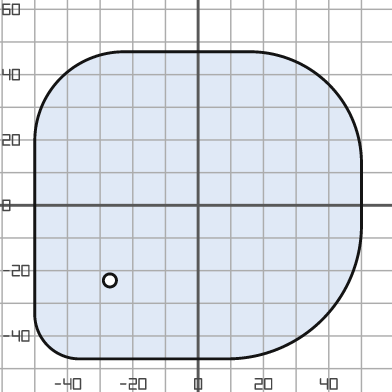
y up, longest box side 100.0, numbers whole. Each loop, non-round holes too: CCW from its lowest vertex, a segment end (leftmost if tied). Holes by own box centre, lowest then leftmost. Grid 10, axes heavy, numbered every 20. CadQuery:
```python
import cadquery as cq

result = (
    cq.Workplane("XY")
    .moveTo(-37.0, -47.0)
    .lineTo(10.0, -47.0)
    .threePointArc((38.0, -35.0), (50.0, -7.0))
    .lineTo(50.0, 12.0)
    .threePointArc((40.0, 37.0), (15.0, 47.0))
    .lineTo(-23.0, 47.0)
    .threePointArc((-42.0, 39.0), (-50.0, 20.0))
    .lineTo(-50.0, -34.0)
    .threePointArc((-46.0, -43.0), (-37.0, -47.0))
    .close()
    .moveTo(-27.0, -23.0)
    .circle(2.0)
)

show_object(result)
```